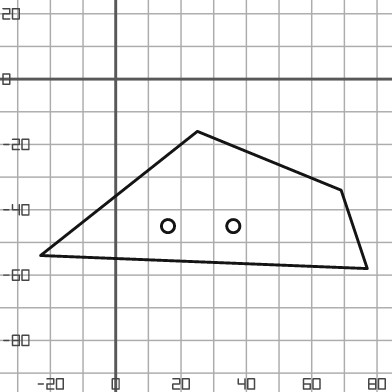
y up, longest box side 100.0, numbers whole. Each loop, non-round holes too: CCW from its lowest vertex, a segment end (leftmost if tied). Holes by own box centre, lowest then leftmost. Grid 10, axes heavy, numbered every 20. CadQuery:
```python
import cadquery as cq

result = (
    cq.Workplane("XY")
    .moveTo(77.0, -58.0)
    .lineTo(69.0, -34.0)
    .lineTo(25.0, -16.0)
    .lineTo(-23.0, -54.0)
    .close()
    .moveTo(16.0, -45.0)
    .circle(2.0)
    .moveTo(36.0, -45.0)
    .circle(2.0)
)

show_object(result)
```